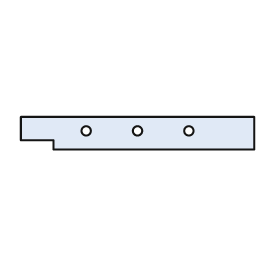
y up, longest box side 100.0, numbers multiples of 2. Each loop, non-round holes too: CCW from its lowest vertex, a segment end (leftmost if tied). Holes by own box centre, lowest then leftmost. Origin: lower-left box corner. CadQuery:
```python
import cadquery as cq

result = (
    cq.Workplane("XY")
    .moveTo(14.0, 0.0)
    .lineTo(100.0, 0.0)
    .lineTo(100.0, 14.0)
    .lineTo(0.0, 14.0)
    .lineTo(0.0, 4.0)
    .lineTo(14.0, 4.0)
    .close()
    .moveTo(28.0, 8.0)
    .circle(2.0)
    .moveTo(50.0, 8.0)
    .circle(2.0)
    .moveTo(72.0, 8.0)
    .circle(2.0)
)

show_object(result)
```